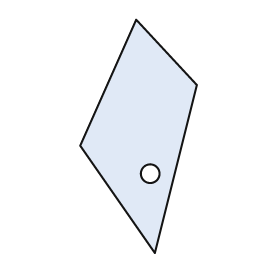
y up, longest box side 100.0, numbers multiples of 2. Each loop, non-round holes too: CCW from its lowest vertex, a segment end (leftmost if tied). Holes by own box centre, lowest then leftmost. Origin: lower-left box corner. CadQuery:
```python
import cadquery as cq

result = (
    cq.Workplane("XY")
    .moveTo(32.0, 0.0)
    .lineTo(50.0, 72.0)
    .lineTo(24.0, 100.0)
    .lineTo(0.0, 46.0)
    .close()
    .moveTo(30.0, 34.0)
    .circle(4.0)
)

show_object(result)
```